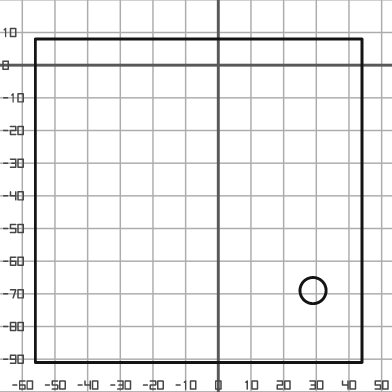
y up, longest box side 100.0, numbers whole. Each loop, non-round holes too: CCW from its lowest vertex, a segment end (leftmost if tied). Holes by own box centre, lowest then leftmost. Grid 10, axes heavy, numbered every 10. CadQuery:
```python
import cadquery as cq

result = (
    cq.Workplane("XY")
    .moveTo(-56.0, -91.0)
    .lineTo(44.0, -91.0)
    .lineTo(44.0, 8.0)
    .lineTo(-56.0, 8.0)
    .close()
    .moveTo(29.0, -69.0)
    .circle(4.0)
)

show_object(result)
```